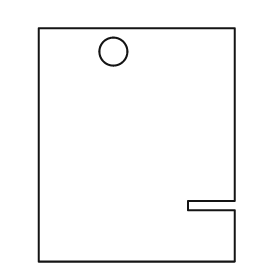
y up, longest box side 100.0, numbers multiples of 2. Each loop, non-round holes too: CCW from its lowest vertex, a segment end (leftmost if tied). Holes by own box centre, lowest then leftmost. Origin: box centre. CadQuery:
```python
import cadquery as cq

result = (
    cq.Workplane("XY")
    .moveTo(-42.0, -50.0)
    .lineTo(42.0, -50.0)
    .lineTo(42.0, -28.0)
    .lineTo(22.0, -28.0)
    .lineTo(22.0, -24.0)
    .lineTo(42.0, -24.0)
    .lineTo(42.0, 50.0)
    .lineTo(-42.0, 50.0)
    .close()
    .moveTo(-10.0, 40.0)
    .circle(6.0)
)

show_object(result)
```